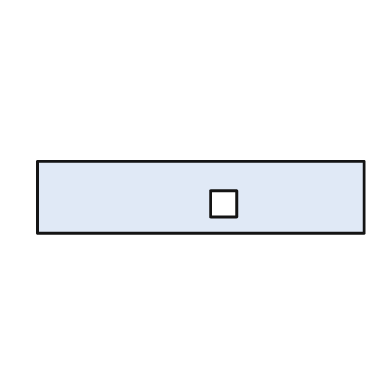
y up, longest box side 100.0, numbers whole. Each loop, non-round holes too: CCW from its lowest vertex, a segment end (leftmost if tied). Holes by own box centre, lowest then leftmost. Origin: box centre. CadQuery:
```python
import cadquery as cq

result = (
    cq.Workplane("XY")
    .moveTo(-50.0, -11.0)
    .lineTo(50.0, -11.0)
    .lineTo(50.0, 11.0)
    .lineTo(-50.0, 11.0)
    .close()
    .moveTo(3.0, -6.0)
    .lineTo(11.0, -6.0)
    .lineTo(11.0, 2.0)
    .lineTo(3.0, 2.0)
    .close()
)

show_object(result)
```